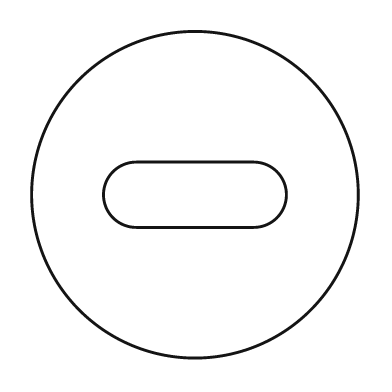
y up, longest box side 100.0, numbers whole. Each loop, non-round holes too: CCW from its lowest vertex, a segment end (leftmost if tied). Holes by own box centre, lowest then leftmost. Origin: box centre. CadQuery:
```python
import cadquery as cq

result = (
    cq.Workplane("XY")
    .moveTo(0.0, 0.0)
    .circle(50.0)
    .moveTo(-18.0, -10.0)
    .lineTo(18.0, -10.0)
    .threePointArc((28.0, 0.0), (18.0, 10.0))
    .lineTo(-18.0, 10.0)
    .threePointArc((-28.0, 0.0), (-18.0, -10.0))
    .close()
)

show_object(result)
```